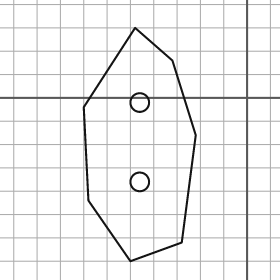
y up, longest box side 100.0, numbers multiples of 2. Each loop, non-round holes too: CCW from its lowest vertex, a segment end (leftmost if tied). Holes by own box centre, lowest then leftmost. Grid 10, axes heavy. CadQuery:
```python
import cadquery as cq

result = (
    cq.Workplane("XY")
    .moveTo(-50.0, -70.0)
    .lineTo(-28.0, -62.0)
    .lineTo(-22.0, -16.0)
    .lineTo(-32.0, 16.0)
    .lineTo(-48.0, 30.0)
    .lineTo(-70.0, -4.0)
    .lineTo(-68.0, -44.0)
    .close()
    .moveTo(-46.0, -36.0)
    .circle(4.0)
    .moveTo(-46.0, -2.0)
    .circle(4.0)
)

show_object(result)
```